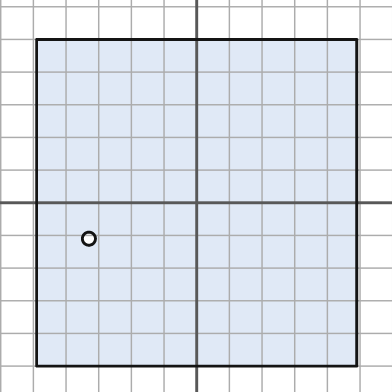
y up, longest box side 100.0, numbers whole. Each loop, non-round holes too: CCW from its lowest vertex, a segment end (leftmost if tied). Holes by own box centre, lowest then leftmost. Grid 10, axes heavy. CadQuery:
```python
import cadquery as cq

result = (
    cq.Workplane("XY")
    .moveTo(-49.0, -50.0)
    .lineTo(49.0, -50.0)
    .lineTo(49.0, 50.0)
    .lineTo(-49.0, 50.0)
    .close()
    .moveTo(-33.0, -11.0)
    .circle(2.0)
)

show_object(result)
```